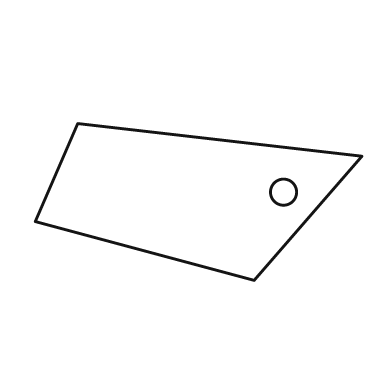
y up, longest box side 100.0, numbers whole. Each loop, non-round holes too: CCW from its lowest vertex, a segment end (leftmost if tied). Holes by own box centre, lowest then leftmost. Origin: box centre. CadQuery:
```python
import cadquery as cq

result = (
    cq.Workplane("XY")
    .moveTo(17.0, -24.0)
    .lineTo(50.0, 14.0)
    .lineTo(-37.0, 24.0)
    .lineTo(-50.0, -6.0)
    .close()
    .moveTo(26.0, 3.0)
    .circle(4.0)
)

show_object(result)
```